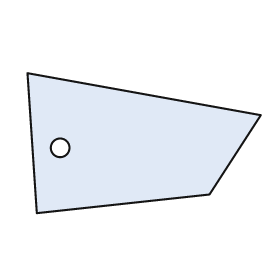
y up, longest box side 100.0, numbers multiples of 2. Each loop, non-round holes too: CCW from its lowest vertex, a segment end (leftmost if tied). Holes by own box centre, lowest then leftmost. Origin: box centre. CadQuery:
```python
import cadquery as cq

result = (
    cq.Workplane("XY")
    .moveTo(-46.0, -30.0)
    .lineTo(28.0, -22.0)
    .lineTo(50.0, 12.0)
    .lineTo(-50.0, 30.0)
    .close()
    .moveTo(-36.0, -2.0)
    .circle(4.0)
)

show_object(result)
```